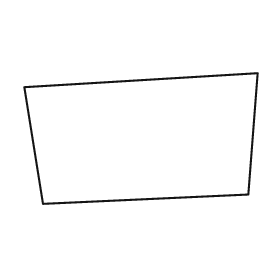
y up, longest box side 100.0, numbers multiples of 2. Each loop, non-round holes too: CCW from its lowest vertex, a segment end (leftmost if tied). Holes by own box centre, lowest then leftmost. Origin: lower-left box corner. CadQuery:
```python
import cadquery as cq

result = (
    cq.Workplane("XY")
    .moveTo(8.0, 0.0)
    .lineTo(96.0, 4.0)
    .lineTo(100.0, 56.0)
    .lineTo(0.0, 50.0)
    .close()
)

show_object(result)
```